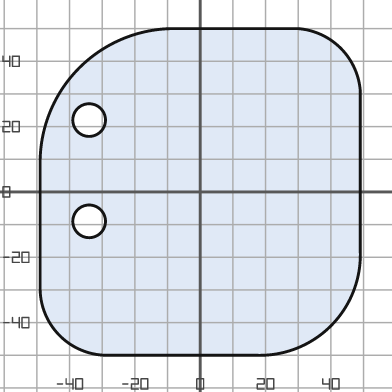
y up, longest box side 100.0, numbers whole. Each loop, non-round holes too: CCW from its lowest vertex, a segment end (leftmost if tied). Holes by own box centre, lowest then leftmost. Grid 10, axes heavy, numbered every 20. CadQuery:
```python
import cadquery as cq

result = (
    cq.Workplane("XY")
    .moveTo(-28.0, -50.0)
    .lineTo(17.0, -50.0)
    .threePointArc((40.0, -41.0), (49.0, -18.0))
    .lineTo(49.0, 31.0)
    .threePointArc((43.0, 44.0), (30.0, 50.0))
    .lineTo(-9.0, 50.0)
    .threePointArc((-37.0, 38.0), (-49.0, 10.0))
    .lineTo(-49.0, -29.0)
    .threePointArc((-43.0, -44.0), (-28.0, -50.0))
    .close()
    .moveTo(-34.0, -9.0)
    .circle(5.0)
    .moveTo(-34.0, 22.0)
    .circle(5.0)
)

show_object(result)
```